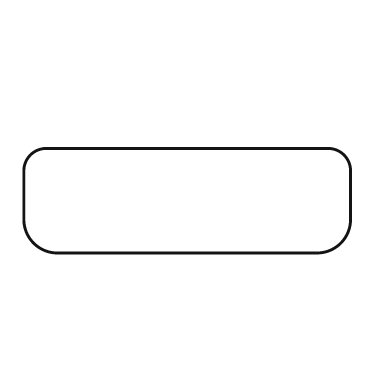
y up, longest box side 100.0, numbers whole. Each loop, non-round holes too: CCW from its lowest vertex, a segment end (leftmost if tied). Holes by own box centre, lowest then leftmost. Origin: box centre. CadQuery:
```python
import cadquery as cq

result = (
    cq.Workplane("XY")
    .moveTo(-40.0, -16.0)
    .lineTo(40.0, -16.0)
    .threePointArc((47.0, -13.0), (50.0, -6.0))
    .lineTo(50.0, 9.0)
    .threePointArc((48.0, 14.0), (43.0, 16.0))
    .lineTo(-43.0, 16.0)
    .threePointArc((-48.0, 14.0), (-50.0, 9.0))
    .lineTo(-50.0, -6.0)
    .threePointArc((-47.0, -13.0), (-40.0, -16.0))
    .close()
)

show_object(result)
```